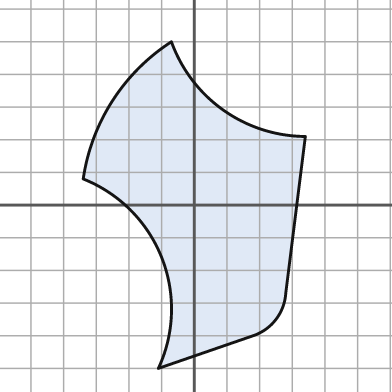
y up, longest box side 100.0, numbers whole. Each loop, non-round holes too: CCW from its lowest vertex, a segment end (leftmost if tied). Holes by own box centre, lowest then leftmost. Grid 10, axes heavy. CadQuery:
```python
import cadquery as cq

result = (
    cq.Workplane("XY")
    .moveTo(-11.0, -50.0)
    .lineTo(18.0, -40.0)
    .threePointArc((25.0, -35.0), (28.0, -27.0))
    .lineTo(34.0, 21.0)
    .threePointArc((9.0, 29.0), (-7.0, 50.0))
    .threePointArc((-25.0, 32.0), (-34.0, 8.0))
    .threePointArc((-10.0, -16.0), (-11.0, -50.0))
    .close()
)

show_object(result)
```